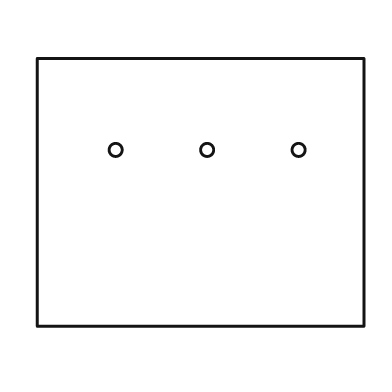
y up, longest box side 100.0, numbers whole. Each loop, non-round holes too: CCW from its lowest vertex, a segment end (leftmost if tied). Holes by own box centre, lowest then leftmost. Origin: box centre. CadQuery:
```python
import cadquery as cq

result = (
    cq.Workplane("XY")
    .moveTo(-50.0, -41.0)
    .lineTo(50.0, -41.0)
    .lineTo(50.0, 41.0)
    .lineTo(-50.0, 41.0)
    .close()
    .moveTo(-26.0, 13.0)
    .circle(2.0)
    .moveTo(2.0, 13.0)
    .circle(2.0)
    .moveTo(30.0, 13.0)
    .circle(2.0)
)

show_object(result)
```